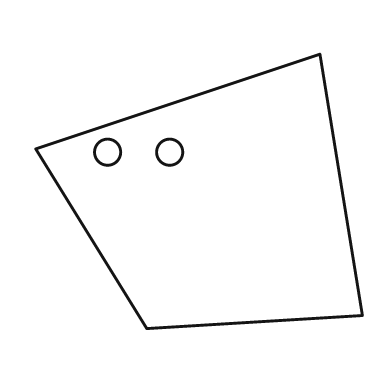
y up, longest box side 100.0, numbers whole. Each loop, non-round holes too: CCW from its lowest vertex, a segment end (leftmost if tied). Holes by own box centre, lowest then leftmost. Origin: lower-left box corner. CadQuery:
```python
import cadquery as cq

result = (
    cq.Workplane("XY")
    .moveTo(34.0, 0.0)
    .lineTo(100.0, 4.0)
    .lineTo(87.0, 84.0)
    .lineTo(0.0, 55.0)
    .close()
    .moveTo(22.0, 54.0)
    .circle(4.0)
    .moveTo(41.0, 54.0)
    .circle(4.0)
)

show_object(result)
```